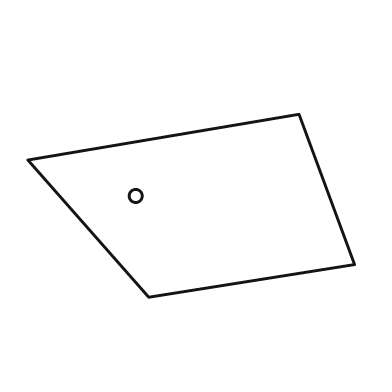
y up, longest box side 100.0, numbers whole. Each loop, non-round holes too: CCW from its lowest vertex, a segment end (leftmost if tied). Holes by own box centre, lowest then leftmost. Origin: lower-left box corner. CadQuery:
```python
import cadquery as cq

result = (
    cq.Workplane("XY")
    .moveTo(37.0, 0.0)
    .lineTo(100.0, 10.0)
    .lineTo(83.0, 56.0)
    .lineTo(0.0, 42.0)
    .close()
    .moveTo(33.0, 31.0)
    .circle(2.0)
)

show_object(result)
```